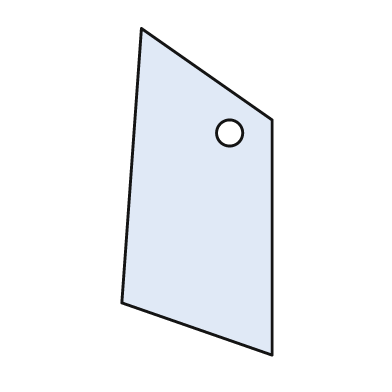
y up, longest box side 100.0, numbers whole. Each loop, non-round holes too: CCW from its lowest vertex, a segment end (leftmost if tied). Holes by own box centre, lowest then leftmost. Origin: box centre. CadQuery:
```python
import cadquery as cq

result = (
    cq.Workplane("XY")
    .moveTo(23.0, -50.0)
    .lineTo(23.0, 22.0)
    .lineTo(-17.0, 50.0)
    .lineTo(-23.0, -34.0)
    .close()
    .moveTo(10.0, 18.0)
    .circle(4.0)
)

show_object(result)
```